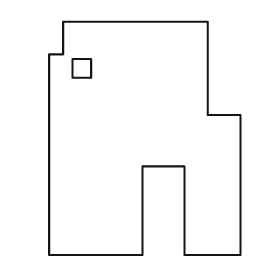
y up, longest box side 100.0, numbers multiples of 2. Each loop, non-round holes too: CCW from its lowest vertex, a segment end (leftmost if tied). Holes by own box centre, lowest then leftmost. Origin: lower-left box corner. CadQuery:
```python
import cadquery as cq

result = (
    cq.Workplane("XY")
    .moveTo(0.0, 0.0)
    .lineTo(40.0, 0.0)
    .lineTo(40.0, 38.0)
    .lineTo(58.0, 38.0)
    .lineTo(58.0, 0.0)
    .lineTo(82.0, 0.0)
    .lineTo(82.0, 60.0)
    .lineTo(68.0, 60.0)
    .lineTo(68.0, 100.0)
    .lineTo(6.0, 100.0)
    .lineTo(6.0, 86.0)
    .lineTo(0.0, 86.0)
    .close()
    .moveTo(10.0, 76.0)
    .lineTo(18.0, 76.0)
    .lineTo(18.0, 84.0)
    .lineTo(10.0, 84.0)
    .close()
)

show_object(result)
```